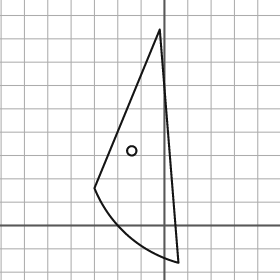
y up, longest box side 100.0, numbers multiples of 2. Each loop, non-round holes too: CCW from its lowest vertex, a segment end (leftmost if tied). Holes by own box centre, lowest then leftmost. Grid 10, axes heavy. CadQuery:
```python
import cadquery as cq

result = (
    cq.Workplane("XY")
    .moveTo(6.0, -16.0)
    .lineTo(-2.0, 84.0)
    .lineTo(-30.0, 16.0)
    .threePointArc((-16.0, -4.0), (6.0, -16.0))
    .close()
    .moveTo(-14.0, 32.0)
    .circle(2.0)
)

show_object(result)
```